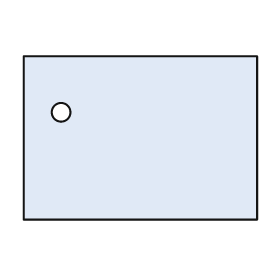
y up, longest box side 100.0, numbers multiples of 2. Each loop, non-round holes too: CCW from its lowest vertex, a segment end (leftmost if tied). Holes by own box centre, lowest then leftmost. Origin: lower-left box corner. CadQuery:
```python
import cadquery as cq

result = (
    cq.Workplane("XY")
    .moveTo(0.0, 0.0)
    .lineTo(100.0, 0.0)
    .lineTo(100.0, 70.0)
    .lineTo(0.0, 70.0)
    .close()
    .moveTo(16.0, 46.0)
    .circle(4.0)
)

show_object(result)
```